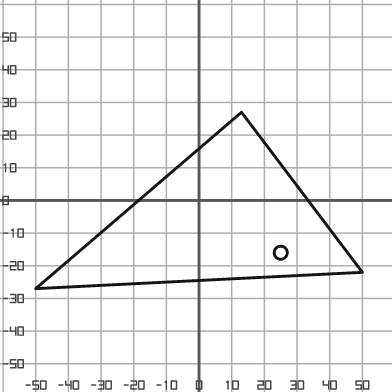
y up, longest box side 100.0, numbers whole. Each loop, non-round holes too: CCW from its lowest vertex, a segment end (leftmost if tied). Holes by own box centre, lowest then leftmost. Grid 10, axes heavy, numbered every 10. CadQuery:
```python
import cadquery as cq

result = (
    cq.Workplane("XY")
    .moveTo(-50.0, -27.0)
    .lineTo(50.0, -22.0)
    .lineTo(13.0, 27.0)
    .close()
    .moveTo(25.0, -16.0)
    .circle(2.0)
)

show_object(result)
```